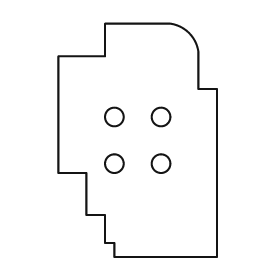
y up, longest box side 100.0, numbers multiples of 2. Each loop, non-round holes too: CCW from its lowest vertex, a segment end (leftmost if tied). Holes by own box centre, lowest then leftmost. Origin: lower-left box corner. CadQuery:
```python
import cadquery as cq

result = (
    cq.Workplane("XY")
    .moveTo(24.0, 0.0)
    .lineTo(68.0, 0.0)
    .lineTo(68.0, 72.0)
    .lineTo(60.0, 72.0)
    .lineTo(60.0, 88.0)
    .threePointArc((56.0, 96.0), (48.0, 100.0))
    .lineTo(20.0, 100.0)
    .lineTo(20.0, 86.0)
    .lineTo(0.0, 86.0)
    .lineTo(0.0, 36.0)
    .lineTo(12.0, 36.0)
    .lineTo(12.0, 18.0)
    .lineTo(20.0, 18.0)
    .lineTo(20.0, 6.0)
    .lineTo(24.0, 6.0)
    .close()
    .moveTo(24.0, 40.0)
    .circle(4.0)
    .moveTo(44.0, 40.0)
    .circle(4.0)
    .moveTo(24.0, 60.0)
    .circle(4.0)
    .moveTo(44.0, 60.0)
    .circle(4.0)
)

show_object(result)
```